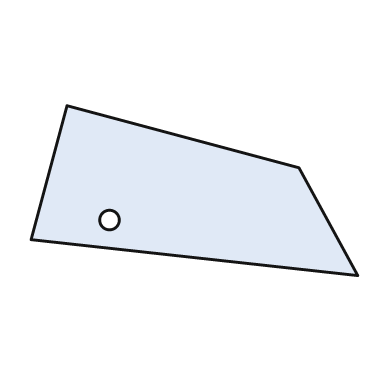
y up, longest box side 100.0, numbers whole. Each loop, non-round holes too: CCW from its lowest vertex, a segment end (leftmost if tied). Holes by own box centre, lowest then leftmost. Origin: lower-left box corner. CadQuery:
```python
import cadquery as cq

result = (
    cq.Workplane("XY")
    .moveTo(100.0, 0.0)
    .lineTo(82.0, 33.0)
    .lineTo(11.0, 52.0)
    .lineTo(0.0, 11.0)
    .close()
    .moveTo(24.0, 17.0)
    .circle(3.0)
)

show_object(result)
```